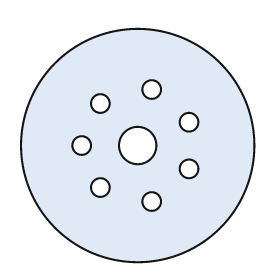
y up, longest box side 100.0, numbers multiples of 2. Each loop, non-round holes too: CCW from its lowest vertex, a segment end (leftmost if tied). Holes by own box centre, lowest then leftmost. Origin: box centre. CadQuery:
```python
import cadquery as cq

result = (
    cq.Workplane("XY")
    .moveTo(0.0, 0.0)
    .circle(50.0)
    .moveTo(6.0, -24.0)
    .circle(4.0)
    .moveTo(-16.0, -18.0)
    .circle(4.0)
    .moveTo(22.0, -10.0)
    .circle(4.0)
    .moveTo(-24.0, 0.0)
    .circle(4.0)
    .moveTo(0.0, 0.0)
    .circle(8.0)
    .moveTo(22.0, 10.0)
    .circle(4.0)
    .moveTo(-16.0, 18.0)
    .circle(4.0)
    .moveTo(6.0, 24.0)
    .circle(4.0)
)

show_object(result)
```